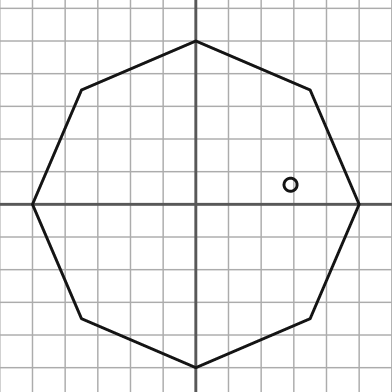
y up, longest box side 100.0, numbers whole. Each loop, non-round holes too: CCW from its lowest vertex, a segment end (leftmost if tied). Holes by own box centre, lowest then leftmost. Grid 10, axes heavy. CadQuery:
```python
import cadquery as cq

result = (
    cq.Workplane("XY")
    .moveTo(0.0, -50.0)
    .lineTo(35.0, -35.0)
    .lineTo(50.0, 0.0)
    .lineTo(35.0, 35.0)
    .lineTo(0.0, 50.0)
    .lineTo(-35.0, 35.0)
    .lineTo(-50.0, 0.0)
    .lineTo(-35.0, -35.0)
    .close()
    .moveTo(29.0, 6.0)
    .circle(2.0)
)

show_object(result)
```